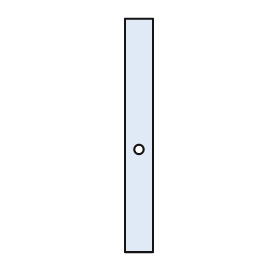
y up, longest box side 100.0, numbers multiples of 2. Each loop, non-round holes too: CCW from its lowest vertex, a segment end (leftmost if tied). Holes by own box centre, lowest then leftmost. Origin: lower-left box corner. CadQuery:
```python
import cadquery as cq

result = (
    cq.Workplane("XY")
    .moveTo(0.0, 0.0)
    .lineTo(12.0, 0.0)
    .lineTo(12.0, 100.0)
    .lineTo(0.0, 100.0)
    .close()
    .moveTo(6.0, 44.0)
    .circle(2.0)
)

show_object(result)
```